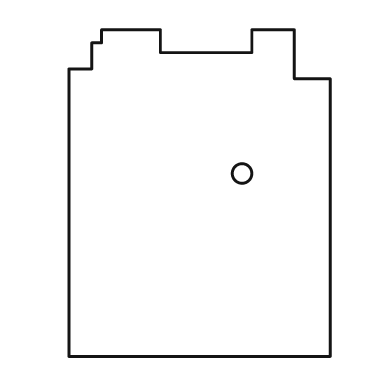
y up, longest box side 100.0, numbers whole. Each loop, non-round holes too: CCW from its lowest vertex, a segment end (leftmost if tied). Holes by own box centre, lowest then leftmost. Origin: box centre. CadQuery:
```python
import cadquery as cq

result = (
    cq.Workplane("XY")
    .moveTo(-40.0, -50.0)
    .lineTo(40.0, -50.0)
    .lineTo(40.0, 35.0)
    .lineTo(29.0, 35.0)
    .lineTo(29.0, 50.0)
    .lineTo(16.0, 50.0)
    .lineTo(16.0, 43.0)
    .lineTo(-12.0, 43.0)
    .lineTo(-12.0, 50.0)
    .lineTo(-30.0, 50.0)
    .lineTo(-30.0, 46.0)
    .lineTo(-33.0, 46.0)
    .lineTo(-33.0, 38.0)
    .lineTo(-40.0, 38.0)
    .close()
    .moveTo(13.0, 6.0)
    .circle(3.0)
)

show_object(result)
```